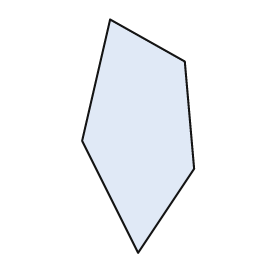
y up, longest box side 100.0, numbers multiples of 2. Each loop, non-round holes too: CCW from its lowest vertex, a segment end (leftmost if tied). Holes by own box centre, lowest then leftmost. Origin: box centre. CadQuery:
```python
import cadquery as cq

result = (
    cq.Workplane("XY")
    .moveTo(0.0, -50.0)
    .lineTo(24.0, -14.0)
    .lineTo(20.0, 32.0)
    .lineTo(-12.0, 50.0)
    .lineTo(-24.0, -2.0)
    .close()
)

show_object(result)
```